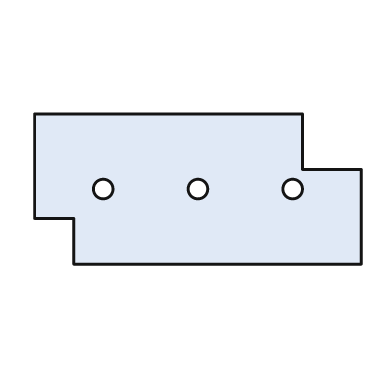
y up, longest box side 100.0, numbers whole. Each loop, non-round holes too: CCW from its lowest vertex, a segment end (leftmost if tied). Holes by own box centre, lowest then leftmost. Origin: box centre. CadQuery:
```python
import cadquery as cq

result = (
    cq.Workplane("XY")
    .moveTo(-38.0, -23.0)
    .lineTo(50.0, -23.0)
    .lineTo(50.0, 6.0)
    .lineTo(32.0, 6.0)
    .lineTo(32.0, 23.0)
    .lineTo(-50.0, 23.0)
    .lineTo(-50.0, -9.0)
    .lineTo(-38.0, -9.0)
    .close()
    .moveTo(-29.0, 0.0)
    .circle(3.0)
    .moveTo(0.0, 0.0)
    .circle(3.0)
    .moveTo(29.0, 0.0)
    .circle(3.0)
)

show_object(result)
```